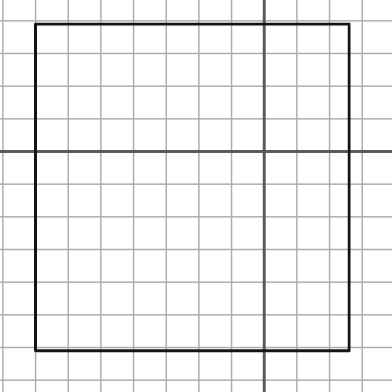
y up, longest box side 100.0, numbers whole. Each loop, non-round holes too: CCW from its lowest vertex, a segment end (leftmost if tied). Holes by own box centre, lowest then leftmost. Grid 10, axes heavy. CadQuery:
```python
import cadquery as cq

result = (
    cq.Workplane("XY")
    .moveTo(-70.0, -61.0)
    .lineTo(26.0, -61.0)
    .lineTo(26.0, 39.0)
    .lineTo(-70.0, 39.0)
    .close()
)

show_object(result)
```